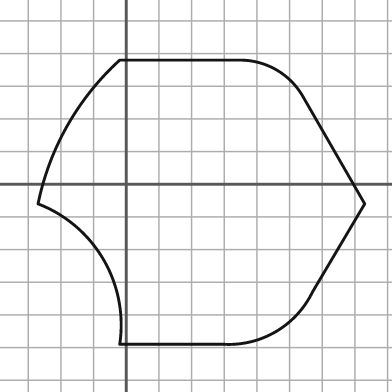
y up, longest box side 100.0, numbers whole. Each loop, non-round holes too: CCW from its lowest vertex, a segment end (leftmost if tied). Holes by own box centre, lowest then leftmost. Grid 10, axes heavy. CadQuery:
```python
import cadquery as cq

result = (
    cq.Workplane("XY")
    .moveTo(-2.0, -49.0)
    .lineTo(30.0, -49.0)
    .threePointArc((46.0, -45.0), (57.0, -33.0))
    .lineTo(73.0, -6.0)
    .lineTo(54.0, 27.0)
    .threePointArc((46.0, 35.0), (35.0, 38.0))
    .lineTo(-2.0, 38.0)
    .threePointArc((-18.0, 18.0), (-27.0, -6.0))
    .threePointArc((-7.0, -23.0), (-2.0, -49.0))
    .close()
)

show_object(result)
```